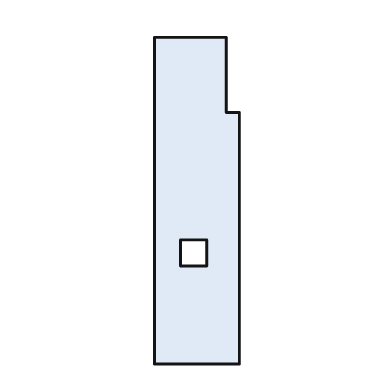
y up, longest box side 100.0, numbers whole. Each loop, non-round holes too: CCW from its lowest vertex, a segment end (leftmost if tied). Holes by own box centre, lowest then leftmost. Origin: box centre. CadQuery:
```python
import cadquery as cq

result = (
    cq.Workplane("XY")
    .moveTo(-13.0, -50.0)
    .lineTo(13.0, -50.0)
    .lineTo(13.0, 27.0)
    .lineTo(9.0, 27.0)
    .lineTo(9.0, 50.0)
    .lineTo(-13.0, 50.0)
    .close()
    .moveTo(-5.0, -20.0)
    .lineTo(3.0, -20.0)
    .lineTo(3.0, -12.0)
    .lineTo(-5.0, -12.0)
    .close()
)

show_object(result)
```